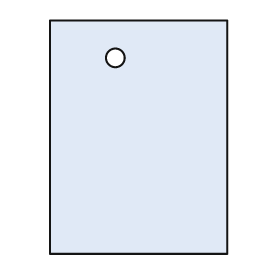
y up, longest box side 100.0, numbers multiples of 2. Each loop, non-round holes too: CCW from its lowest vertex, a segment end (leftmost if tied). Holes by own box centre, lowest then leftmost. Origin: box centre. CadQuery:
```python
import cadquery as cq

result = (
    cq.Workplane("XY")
    .moveTo(-38.0, -50.0)
    .lineTo(38.0, -50.0)
    .lineTo(38.0, 50.0)
    .lineTo(-38.0, 50.0)
    .close()
    .moveTo(-10.0, 34.0)
    .circle(4.0)
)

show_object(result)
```